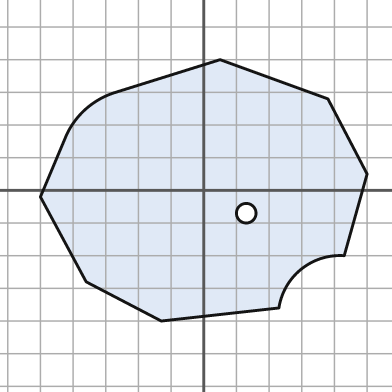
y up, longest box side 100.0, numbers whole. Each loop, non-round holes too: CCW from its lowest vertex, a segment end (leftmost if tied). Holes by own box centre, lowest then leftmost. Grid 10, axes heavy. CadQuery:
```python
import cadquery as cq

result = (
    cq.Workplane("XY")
    .moveTo(-13.0, -40.0)
    .lineTo(23.0, -36.0)
    .threePointArc((30.0, -24.0), (43.0, -20.0))
    .lineTo(50.0, 5.0)
    .lineTo(38.0, 28.0)
    .lineTo(5.0, 40.0)
    .lineTo(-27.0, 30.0)
    .threePointArc((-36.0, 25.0), (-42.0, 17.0))
    .lineTo(-50.0, -2.0)
    .lineTo(-36.0, -28.0)
    .close()
    .moveTo(13.0, -7.0)
    .circle(3.0)
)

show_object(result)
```